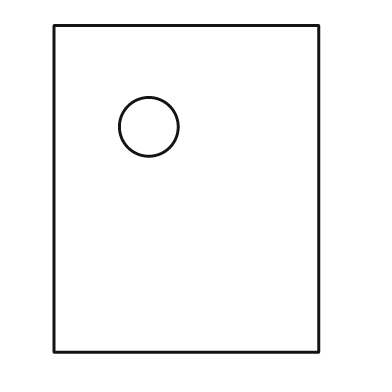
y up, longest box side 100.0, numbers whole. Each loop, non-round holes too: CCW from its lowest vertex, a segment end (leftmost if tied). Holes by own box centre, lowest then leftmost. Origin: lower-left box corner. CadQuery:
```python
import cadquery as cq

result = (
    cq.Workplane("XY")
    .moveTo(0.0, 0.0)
    .lineTo(81.0, 0.0)
    .lineTo(81.0, 100.0)
    .lineTo(0.0, 100.0)
    .close()
    .moveTo(29.0, 69.0)
    .circle(9.0)
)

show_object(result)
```